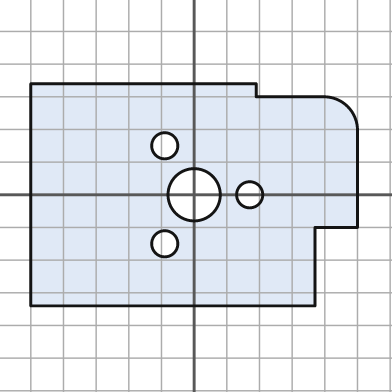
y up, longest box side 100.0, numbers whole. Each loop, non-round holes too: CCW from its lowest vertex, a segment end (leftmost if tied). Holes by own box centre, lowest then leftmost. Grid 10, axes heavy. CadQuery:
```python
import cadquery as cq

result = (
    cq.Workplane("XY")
    .moveTo(-50.0, -34.0)
    .lineTo(37.0, -34.0)
    .lineTo(37.0, -10.0)
    .lineTo(50.0, -10.0)
    .lineTo(50.0, 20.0)
    .threePointArc((47.0, 27.0), (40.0, 30.0))
    .lineTo(19.0, 30.0)
    .lineTo(19.0, 34.0)
    .lineTo(-50.0, 34.0)
    .close()
    .moveTo(-9.0, -15.0)
    .circle(4.0)
    .moveTo(0.0, 0.0)
    .circle(8.0)
    .moveTo(17.0, 0.0)
    .circle(4.0)
    .moveTo(-9.0, 15.0)
    .circle(4.0)
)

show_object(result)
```